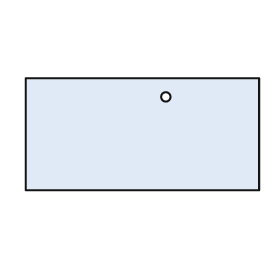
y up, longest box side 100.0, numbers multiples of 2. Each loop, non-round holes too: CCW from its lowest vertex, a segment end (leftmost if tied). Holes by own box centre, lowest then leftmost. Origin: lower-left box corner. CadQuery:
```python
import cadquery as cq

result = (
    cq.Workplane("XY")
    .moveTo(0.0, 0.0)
    .lineTo(100.0, 0.0)
    .lineTo(100.0, 48.0)
    .lineTo(0.0, 48.0)
    .close()
    .moveTo(60.0, 40.0)
    .circle(2.0)
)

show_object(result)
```